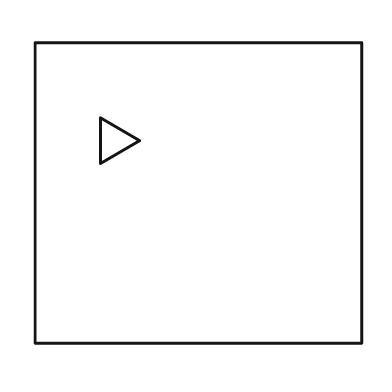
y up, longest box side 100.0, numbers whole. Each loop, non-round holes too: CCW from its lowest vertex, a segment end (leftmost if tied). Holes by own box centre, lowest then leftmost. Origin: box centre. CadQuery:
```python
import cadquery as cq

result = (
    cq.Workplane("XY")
    .moveTo(-50.0, -46.0)
    .lineTo(50.0, -46.0)
    .lineTo(50.0, 46.0)
    .lineTo(-50.0, 46.0)
    .close()
    .moveTo(-30.0, 9.0)
    .lineTo(-18.0, 16.0)
    .lineTo(-30.0, 23.0)
    .close()
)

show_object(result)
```